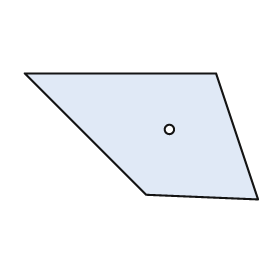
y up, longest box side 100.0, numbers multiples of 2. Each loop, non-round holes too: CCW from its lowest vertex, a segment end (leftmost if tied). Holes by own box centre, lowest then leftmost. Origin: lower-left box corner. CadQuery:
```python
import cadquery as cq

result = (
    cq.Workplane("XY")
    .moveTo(100.0, 0.0)
    .lineTo(82.0, 54.0)
    .lineTo(0.0, 54.0)
    .lineTo(52.0, 2.0)
    .close()
    .moveTo(62.0, 30.0)
    .circle(2.0)
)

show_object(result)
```